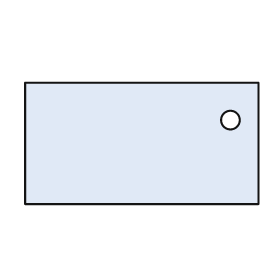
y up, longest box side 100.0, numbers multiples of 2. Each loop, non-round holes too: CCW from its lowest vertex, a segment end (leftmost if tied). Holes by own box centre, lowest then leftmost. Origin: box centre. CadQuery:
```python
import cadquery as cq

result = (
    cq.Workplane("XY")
    .moveTo(-50.0, -26.0)
    .lineTo(50.0, -26.0)
    .lineTo(50.0, 26.0)
    .lineTo(-50.0, 26.0)
    .close()
    .moveTo(38.0, 10.0)
    .circle(4.0)
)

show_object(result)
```